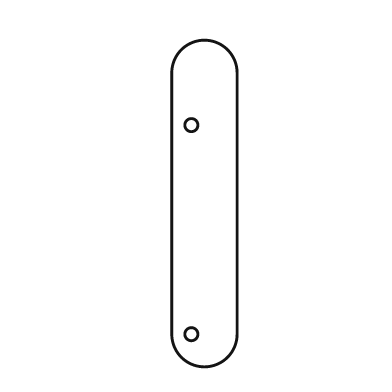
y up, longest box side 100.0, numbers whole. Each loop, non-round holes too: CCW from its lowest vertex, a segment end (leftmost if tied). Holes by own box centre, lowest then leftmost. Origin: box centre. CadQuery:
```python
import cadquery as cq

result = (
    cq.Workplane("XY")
    .moveTo(-10.0, -40.0)
    .threePointArc((0.0, -50.0), (10.0, -40.0))
    .lineTo(10.0, 40.0)
    .threePointArc((0.0, 50.0), (-10.0, 40.0))
    .close()
    .moveTo(-4.0, -40.0)
    .circle(2.0)
    .moveTo(-4.0, 24.0)
    .circle(2.0)
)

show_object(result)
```